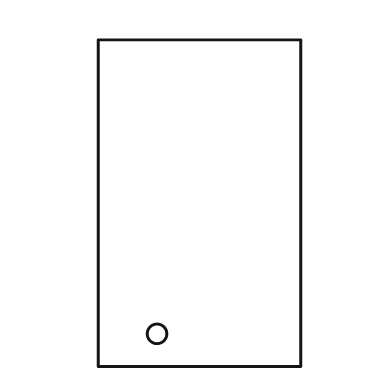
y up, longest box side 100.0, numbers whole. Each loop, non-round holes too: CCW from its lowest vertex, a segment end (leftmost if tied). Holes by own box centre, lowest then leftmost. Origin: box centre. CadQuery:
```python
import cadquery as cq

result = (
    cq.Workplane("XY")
    .moveTo(-31.0, -50.0)
    .lineTo(31.0, -50.0)
    .lineTo(31.0, 50.0)
    .lineTo(-31.0, 50.0)
    .close()
    .moveTo(-13.0, -40.0)
    .circle(3.0)
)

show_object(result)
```